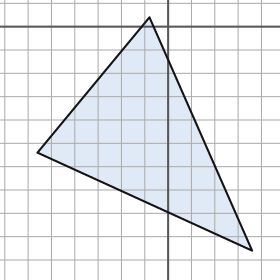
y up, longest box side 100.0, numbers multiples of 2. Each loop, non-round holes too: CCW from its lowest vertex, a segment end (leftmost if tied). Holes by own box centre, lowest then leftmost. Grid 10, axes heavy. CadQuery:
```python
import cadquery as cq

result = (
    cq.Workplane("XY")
    .moveTo(36.0, -96.0)
    .lineTo(-8.0, 4.0)
    .lineTo(-56.0, -54.0)
    .close()
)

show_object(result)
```